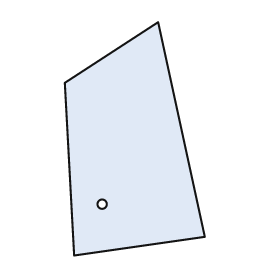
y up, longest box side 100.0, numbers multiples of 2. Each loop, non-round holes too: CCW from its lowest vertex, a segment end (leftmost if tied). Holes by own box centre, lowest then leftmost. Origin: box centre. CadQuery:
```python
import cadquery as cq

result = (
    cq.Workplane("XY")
    .moveTo(-26.0, -50.0)
    .lineTo(30.0, -42.0)
    .lineTo(10.0, 50.0)
    .lineTo(-30.0, 24.0)
    .close()
    .moveTo(-14.0, -28.0)
    .circle(2.0)
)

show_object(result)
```